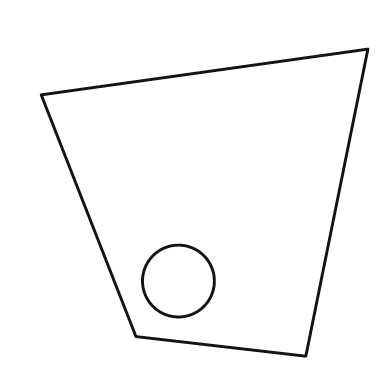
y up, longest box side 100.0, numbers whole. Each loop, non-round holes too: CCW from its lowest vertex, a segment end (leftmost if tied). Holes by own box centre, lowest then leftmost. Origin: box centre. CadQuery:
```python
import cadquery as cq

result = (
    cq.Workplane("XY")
    .moveTo(31.0, -47.0)
    .lineTo(50.0, 47.0)
    .lineTo(-50.0, 33.0)
    .lineTo(-21.0, -41.0)
    .close()
    .moveTo(-8.0, -24.0)
    .circle(11.0)
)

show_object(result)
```